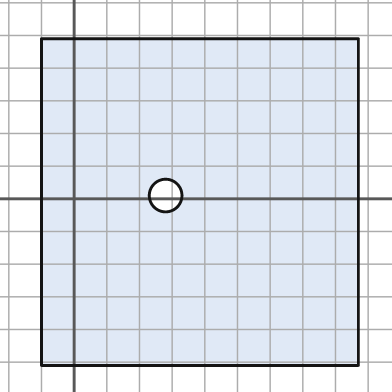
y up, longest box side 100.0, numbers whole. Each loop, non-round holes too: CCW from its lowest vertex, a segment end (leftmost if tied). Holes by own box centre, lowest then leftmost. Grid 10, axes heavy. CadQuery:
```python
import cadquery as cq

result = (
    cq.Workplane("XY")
    .moveTo(-10.0, -51.0)
    .lineTo(87.0, -51.0)
    .lineTo(87.0, 49.0)
    .lineTo(-10.0, 49.0)
    .close()
    .moveTo(28.0, 1.0)
    .circle(5.0)
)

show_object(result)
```